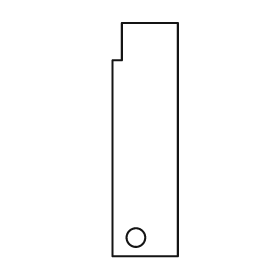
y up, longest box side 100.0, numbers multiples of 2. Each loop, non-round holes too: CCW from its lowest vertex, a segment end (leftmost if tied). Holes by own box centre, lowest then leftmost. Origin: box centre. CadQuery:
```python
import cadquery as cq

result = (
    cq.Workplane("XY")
    .moveTo(-14.0, -50.0)
    .lineTo(14.0, -50.0)
    .lineTo(14.0, 50.0)
    .lineTo(-10.0, 50.0)
    .lineTo(-10.0, 34.0)
    .lineTo(-14.0, 34.0)
    .close()
    .moveTo(-4.0, -42.0)
    .circle(4.0)
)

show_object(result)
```